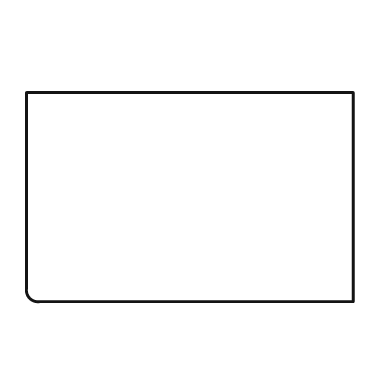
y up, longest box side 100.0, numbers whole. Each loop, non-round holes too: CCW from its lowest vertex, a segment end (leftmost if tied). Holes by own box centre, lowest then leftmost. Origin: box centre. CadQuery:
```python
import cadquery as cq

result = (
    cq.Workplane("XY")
    .moveTo(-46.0, -32.0)
    .lineTo(50.0, -32.0)
    .lineTo(50.0, 32.0)
    .lineTo(-50.0, 32.0)
    .lineTo(-50.0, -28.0)
    .threePointArc((-49.0, -31.0), (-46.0, -32.0))
    .close()
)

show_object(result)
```